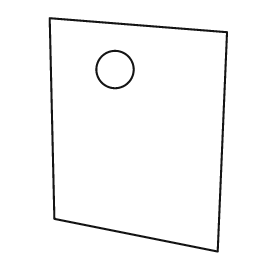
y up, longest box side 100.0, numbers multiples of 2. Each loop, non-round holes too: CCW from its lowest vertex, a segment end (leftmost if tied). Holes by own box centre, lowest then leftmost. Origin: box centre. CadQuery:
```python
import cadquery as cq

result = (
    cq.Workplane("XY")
    .moveTo(34.0, -50.0)
    .lineTo(38.0, 44.0)
    .lineTo(-38.0, 50.0)
    .lineTo(-36.0, -36.0)
    .close()
    .moveTo(-10.0, 28.0)
    .circle(8.0)
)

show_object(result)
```